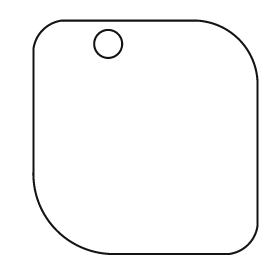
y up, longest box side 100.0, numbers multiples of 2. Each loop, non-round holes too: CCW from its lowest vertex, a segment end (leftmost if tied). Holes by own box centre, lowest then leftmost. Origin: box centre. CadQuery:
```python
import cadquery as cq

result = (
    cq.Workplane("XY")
    .moveTo(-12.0, -50.0)
    .lineTo(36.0, -50.0)
    .threePointArc((44.0, -46.0), (48.0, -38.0))
    .lineTo(48.0, 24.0)
    .threePointArc((40.0, 42.0), (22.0, 50.0))
    .lineTo(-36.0, 50.0)
    .threePointArc((-44.0, 46.0), (-48.0, 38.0))
    .lineTo(-48.0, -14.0)
    .threePointArc((-38.0, -40.0), (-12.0, -50.0))
    .close()
    .moveTo(-16.0, 40.0)
    .circle(6.0)
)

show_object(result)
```